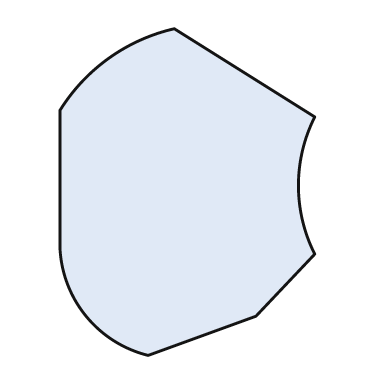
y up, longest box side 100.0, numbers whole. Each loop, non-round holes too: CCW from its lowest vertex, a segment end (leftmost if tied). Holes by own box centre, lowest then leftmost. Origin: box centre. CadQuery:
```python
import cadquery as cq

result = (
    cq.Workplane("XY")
    .moveTo(-12.0, -50.0)
    .lineTo(21.0, -38.0)
    .lineTo(39.0, -19.0)
    .threePointArc((34.0, 2.0), (39.0, 23.0))
    .lineTo(-4.0, 50.0)
    .threePointArc((-24.0, 41.0), (-39.0, 25.0))
    .lineTo(-39.0, -17.0)
    .threePointArc((-31.0, -38.0), (-12.0, -50.0))
    .close()
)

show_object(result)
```